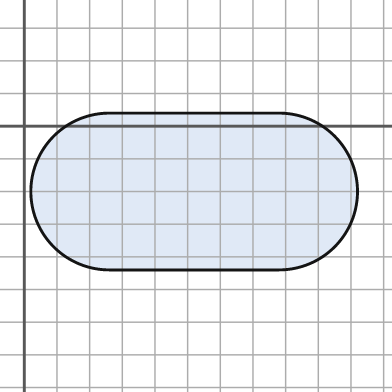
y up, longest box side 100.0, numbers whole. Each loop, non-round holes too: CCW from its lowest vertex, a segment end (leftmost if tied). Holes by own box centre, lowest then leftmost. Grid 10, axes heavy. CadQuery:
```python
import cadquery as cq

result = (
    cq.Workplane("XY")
    .moveTo(26.0, -44.0)
    .lineTo(78.0, -44.0)
    .threePointArc((102.0, -20.0), (78.0, 4.0))
    .lineTo(26.0, 4.0)
    .threePointArc((2.0, -20.0), (26.0, -44.0))
    .close()
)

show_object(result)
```